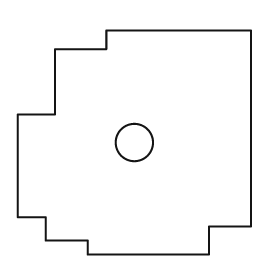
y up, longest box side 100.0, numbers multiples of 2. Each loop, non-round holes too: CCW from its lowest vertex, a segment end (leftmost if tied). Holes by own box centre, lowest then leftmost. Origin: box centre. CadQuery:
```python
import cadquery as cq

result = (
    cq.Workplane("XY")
    .moveTo(-20.0, -48.0)
    .lineTo(32.0, -48.0)
    .lineTo(32.0, -36.0)
    .lineTo(50.0, -36.0)
    .lineTo(50.0, 48.0)
    .lineTo(-12.0, 48.0)
    .lineTo(-12.0, 40.0)
    .lineTo(-34.0, 40.0)
    .lineTo(-34.0, 12.0)
    .lineTo(-50.0, 12.0)
    .lineTo(-50.0, -32.0)
    .lineTo(-38.0, -32.0)
    .lineTo(-38.0, -42.0)
    .lineTo(-20.0, -42.0)
    .close()
    .moveTo(0.0, 0.0)
    .circle(8.0)
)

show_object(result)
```